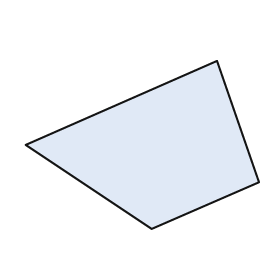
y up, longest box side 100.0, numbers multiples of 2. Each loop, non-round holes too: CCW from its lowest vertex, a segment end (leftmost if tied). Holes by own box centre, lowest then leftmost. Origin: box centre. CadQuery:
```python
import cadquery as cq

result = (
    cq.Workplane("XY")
    .moveTo(4.0, -36.0)
    .lineTo(50.0, -16.0)
    .lineTo(32.0, 36.0)
    .lineTo(-50.0, 0.0)
    .close()
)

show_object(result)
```